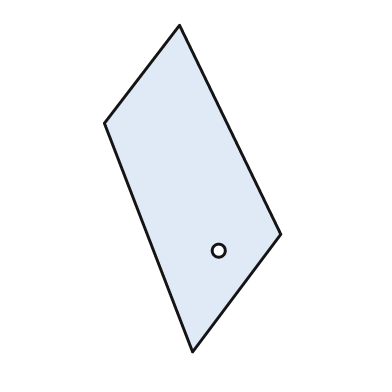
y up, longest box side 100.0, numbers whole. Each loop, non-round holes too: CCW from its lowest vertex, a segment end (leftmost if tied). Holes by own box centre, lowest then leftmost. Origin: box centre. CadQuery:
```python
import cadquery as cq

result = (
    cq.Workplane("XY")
    .moveTo(0.0, -50.0)
    .lineTo(27.0, -14.0)
    .lineTo(-4.0, 50.0)
    .lineTo(-27.0, 20.0)
    .close()
    .moveTo(8.0, -19.0)
    .circle(2.0)
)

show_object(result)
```